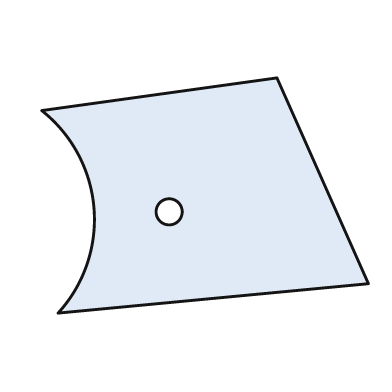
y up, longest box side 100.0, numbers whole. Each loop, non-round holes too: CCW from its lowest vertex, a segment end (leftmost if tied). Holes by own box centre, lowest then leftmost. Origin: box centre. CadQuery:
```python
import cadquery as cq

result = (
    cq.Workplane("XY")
    .moveTo(-45.0, -36.0)
    .lineTo(50.0, -27.0)
    .lineTo(22.0, 36.0)
    .lineTo(-50.0, 26.0)
    .threePointArc((-34.0, -4.0), (-45.0, -36.0))
    .close()
    .moveTo(-11.0, -5.0)
    .circle(4.0)
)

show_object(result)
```